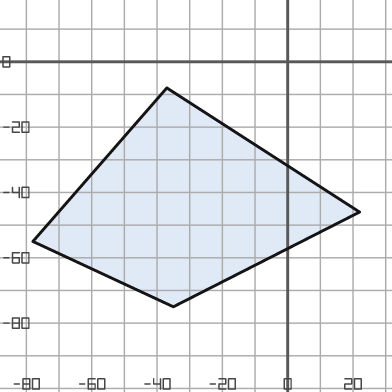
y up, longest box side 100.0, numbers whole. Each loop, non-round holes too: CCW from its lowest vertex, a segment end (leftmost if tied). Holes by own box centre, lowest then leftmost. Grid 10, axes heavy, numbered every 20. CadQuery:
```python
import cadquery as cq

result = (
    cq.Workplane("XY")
    .moveTo(-35.0, -75.0)
    .lineTo(22.0, -46.0)
    .lineTo(-37.0, -8.0)
    .lineTo(-78.0, -55.0)
    .close()
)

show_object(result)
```